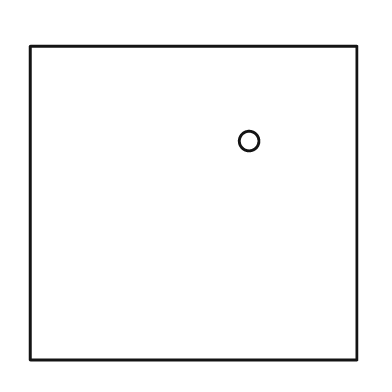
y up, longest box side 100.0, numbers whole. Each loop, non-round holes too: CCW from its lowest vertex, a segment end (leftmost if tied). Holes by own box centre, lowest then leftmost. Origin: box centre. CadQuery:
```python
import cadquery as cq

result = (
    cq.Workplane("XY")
    .moveTo(-50.0, -48.0)
    .lineTo(50.0, -48.0)
    .lineTo(50.0, 48.0)
    .lineTo(-50.0, 48.0)
    .close()
    .moveTo(17.0, 19.0)
    .circle(3.0)
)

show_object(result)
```